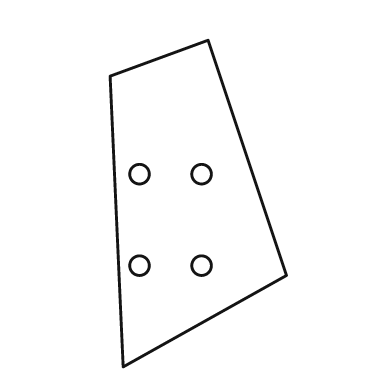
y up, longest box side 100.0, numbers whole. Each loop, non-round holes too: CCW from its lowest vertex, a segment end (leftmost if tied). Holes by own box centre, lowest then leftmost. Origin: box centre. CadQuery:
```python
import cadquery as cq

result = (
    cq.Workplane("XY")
    .moveTo(-23.0, -50.0)
    .lineTo(27.0, -22.0)
    .lineTo(3.0, 50.0)
    .lineTo(-27.0, 39.0)
    .close()
    .moveTo(-18.0, -19.0)
    .circle(3.0)
    .moveTo(1.0, -19.0)
    .circle(3.0)
    .moveTo(-18.0, 9.0)
    .circle(3.0)
    .moveTo(1.0, 9.0)
    .circle(3.0)
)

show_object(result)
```